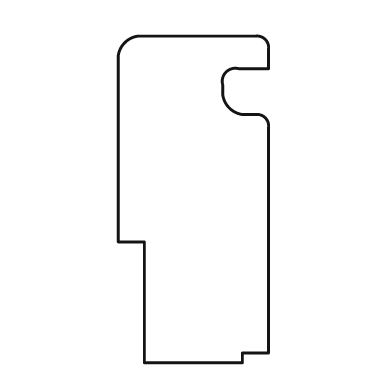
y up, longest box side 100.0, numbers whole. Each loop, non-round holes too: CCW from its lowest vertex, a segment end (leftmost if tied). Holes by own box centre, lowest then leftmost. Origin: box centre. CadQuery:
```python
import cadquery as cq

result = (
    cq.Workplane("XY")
    .moveTo(-15.0, -50.0)
    .lineTo(15.0, -50.0)
    .lineTo(15.0, -47.0)
    .lineTo(23.0, -47.0)
    .lineTo(23.0, 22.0)
    .threePointArc((22.0, 25.0), (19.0, 26.0))
    .lineTo(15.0, 26.0)
    .threePointArc((11.0, 28.0), (9.0, 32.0))
    .lineTo(9.0, 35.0)
    .threePointArc((10.0, 39.0), (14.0, 40.0))
    .lineTo(23.0, 40.0)
    .lineTo(23.0, 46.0)
    .threePointArc((22.0, 49.0), (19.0, 50.0))
    .lineTo(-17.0, 50.0)
    .threePointArc((-21.0, 48.0), (-23.0, 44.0))
    .lineTo(-23.0, -13.0)
    .lineTo(-15.0, -13.0)
    .close()
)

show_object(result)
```